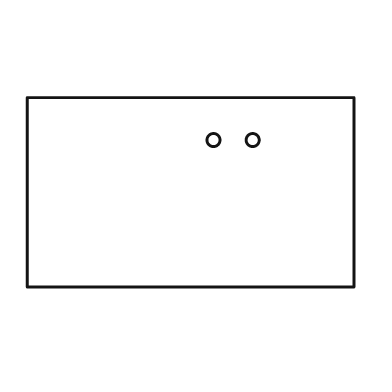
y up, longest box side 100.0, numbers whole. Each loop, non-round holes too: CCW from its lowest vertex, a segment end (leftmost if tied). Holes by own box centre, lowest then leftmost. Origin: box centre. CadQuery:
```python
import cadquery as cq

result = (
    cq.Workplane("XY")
    .moveTo(-50.0, -29.0)
    .lineTo(50.0, -29.0)
    .lineTo(50.0, 29.0)
    .lineTo(-50.0, 29.0)
    .close()
    .moveTo(7.0, 16.0)
    .circle(2.0)
    .moveTo(19.0, 16.0)
    .circle(2.0)
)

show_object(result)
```